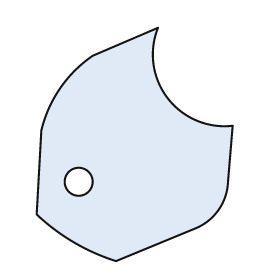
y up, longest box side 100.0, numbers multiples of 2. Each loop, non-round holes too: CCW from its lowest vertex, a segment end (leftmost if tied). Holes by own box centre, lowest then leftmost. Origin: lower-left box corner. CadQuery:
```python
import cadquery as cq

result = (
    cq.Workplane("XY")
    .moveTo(34.0, 0.0)
    .lineTo(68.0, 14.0)
    .threePointArc((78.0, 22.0), (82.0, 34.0))
    .lineTo(84.0, 58.0)
    .threePointArc((56.0, 70.0), (52.0, 100.0))
    .lineTo(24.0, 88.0)
    .threePointArc((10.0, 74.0), (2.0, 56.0))
    .lineTo(0.0, 20.0)
    .threePointArc((16.0, 8.0), (34.0, 0.0))
    .close()
    .moveTo(18.0, 34.0)
    .circle(6.0)
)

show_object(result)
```